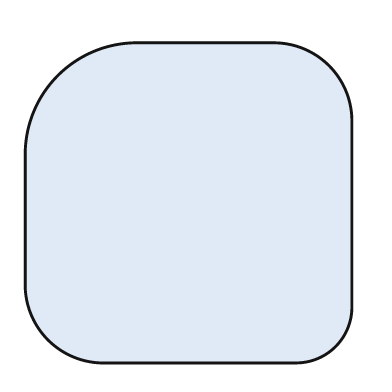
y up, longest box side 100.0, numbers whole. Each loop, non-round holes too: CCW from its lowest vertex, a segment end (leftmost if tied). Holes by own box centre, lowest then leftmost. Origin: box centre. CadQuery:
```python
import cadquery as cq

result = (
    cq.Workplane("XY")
    .moveTo(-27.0, -49.0)
    .lineTo(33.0, -49.0)
    .threePointArc((45.0, -44.0), (50.0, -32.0))
    .lineTo(50.0, 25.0)
    .threePointArc((43.0, 42.0), (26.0, 49.0))
    .lineTo(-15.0, 49.0)
    .threePointArc((-40.0, 39.0), (-50.0, 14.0))
    .lineTo(-50.0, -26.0)
    .threePointArc((-43.0, -42.0), (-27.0, -49.0))
    .close()
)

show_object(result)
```